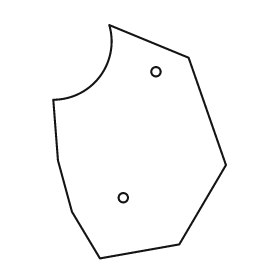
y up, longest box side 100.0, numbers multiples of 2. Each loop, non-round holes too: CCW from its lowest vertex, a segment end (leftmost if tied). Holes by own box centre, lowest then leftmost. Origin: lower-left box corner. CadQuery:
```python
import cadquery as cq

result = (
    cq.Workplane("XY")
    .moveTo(20.0, 0.0)
    .lineTo(54.0, 6.0)
    .lineTo(74.0, 40.0)
    .lineTo(58.0, 86.0)
    .lineTo(24.0, 100.0)
    .threePointArc((20.0, 78.0), (0.0, 68.0))
    .lineTo(2.0, 42.0)
    .lineTo(8.0, 20.0)
    .close()
    .moveTo(30.0, 26.0)
    .circle(2.0)
    .moveTo(44.0, 80.0)
    .circle(2.0)
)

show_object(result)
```